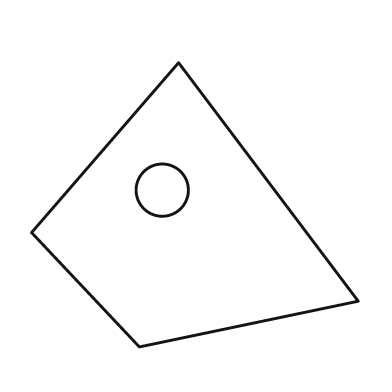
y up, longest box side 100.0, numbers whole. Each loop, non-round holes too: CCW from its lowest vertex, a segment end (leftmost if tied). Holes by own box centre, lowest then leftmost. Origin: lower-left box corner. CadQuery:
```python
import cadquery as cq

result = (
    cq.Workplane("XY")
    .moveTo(33.0, 0.0)
    .lineTo(100.0, 14.0)
    .lineTo(45.0, 87.0)
    .lineTo(0.0, 35.0)
    .close()
    .moveTo(40.0, 48.0)
    .circle(8.0)
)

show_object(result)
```